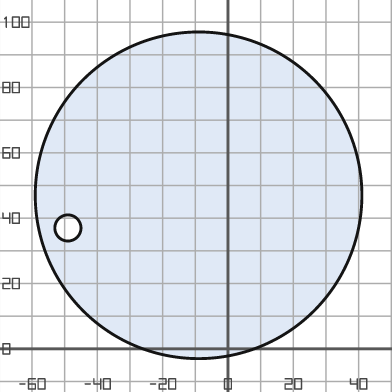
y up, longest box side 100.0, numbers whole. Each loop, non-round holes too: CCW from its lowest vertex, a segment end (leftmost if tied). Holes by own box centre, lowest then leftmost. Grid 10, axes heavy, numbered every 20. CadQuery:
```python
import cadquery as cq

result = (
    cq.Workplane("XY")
    .moveTo(-9.0, 47.0)
    .circle(50.0)
    .moveTo(-49.0, 37.0)
    .circle(4.0)
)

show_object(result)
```